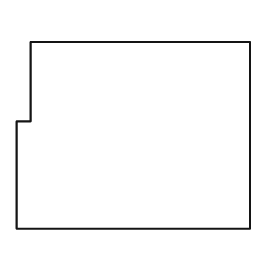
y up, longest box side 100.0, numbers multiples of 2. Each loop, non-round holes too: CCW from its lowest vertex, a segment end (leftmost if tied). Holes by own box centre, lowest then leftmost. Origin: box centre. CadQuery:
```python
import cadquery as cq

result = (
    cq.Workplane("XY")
    .moveTo(-50.0, -40.0)
    .lineTo(50.0, -40.0)
    .lineTo(50.0, 40.0)
    .lineTo(-44.0, 40.0)
    .lineTo(-44.0, 6.0)
    .lineTo(-50.0, 6.0)
    .close()
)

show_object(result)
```